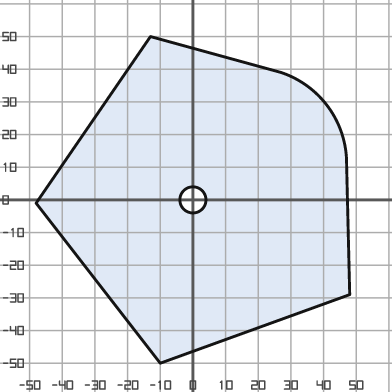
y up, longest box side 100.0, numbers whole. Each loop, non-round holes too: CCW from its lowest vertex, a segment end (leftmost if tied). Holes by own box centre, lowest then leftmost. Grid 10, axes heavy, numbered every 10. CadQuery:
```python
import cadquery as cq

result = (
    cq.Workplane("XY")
    .moveTo(-10.0, -50.0)
    .lineTo(48.0, -29.0)
    .lineTo(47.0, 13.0)
    .threePointArc((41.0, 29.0), (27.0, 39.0))
    .lineTo(-13.0, 50.0)
    .lineTo(-48.0, -1.0)
    .close()
    .moveTo(0.0, 0.0)
    .circle(4.0)
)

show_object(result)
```